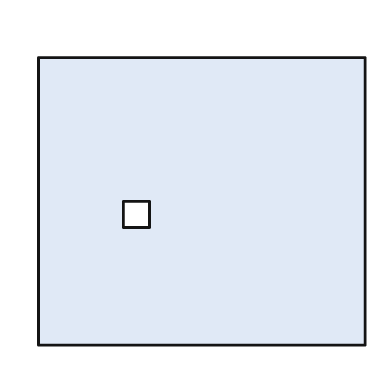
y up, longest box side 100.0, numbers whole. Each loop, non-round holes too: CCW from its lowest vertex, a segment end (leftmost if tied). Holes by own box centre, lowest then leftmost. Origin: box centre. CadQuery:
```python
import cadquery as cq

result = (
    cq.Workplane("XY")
    .moveTo(-50.0, -44.0)
    .lineTo(50.0, -44.0)
    .lineTo(50.0, 44.0)
    .lineTo(-50.0, 44.0)
    .close()
    .moveTo(-24.0, -8.0)
    .lineTo(-16.0, -8.0)
    .lineTo(-16.0, 0.0)
    .lineTo(-24.0, 0.0)
    .close()
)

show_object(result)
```